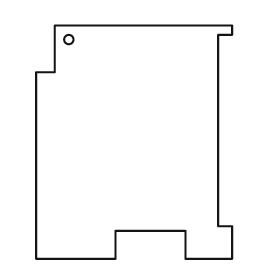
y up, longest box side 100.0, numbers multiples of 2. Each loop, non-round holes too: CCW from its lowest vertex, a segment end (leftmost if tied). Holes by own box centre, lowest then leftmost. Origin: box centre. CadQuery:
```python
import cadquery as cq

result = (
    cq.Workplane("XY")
    .moveTo(-42.0, -50.0)
    .lineTo(-8.0, -50.0)
    .lineTo(-8.0, -38.0)
    .lineTo(22.0, -38.0)
    .lineTo(22.0, -50.0)
    .lineTo(42.0, -50.0)
    .lineTo(42.0, -36.0)
    .lineTo(36.0, -36.0)
    .lineTo(36.0, 46.0)
    .lineTo(42.0, 46.0)
    .lineTo(42.0, 50.0)
    .lineTo(-34.0, 50.0)
    .lineTo(-34.0, 30.0)
    .lineTo(-42.0, 30.0)
    .close()
    .moveTo(-28.0, 44.0)
    .circle(2.0)
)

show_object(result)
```